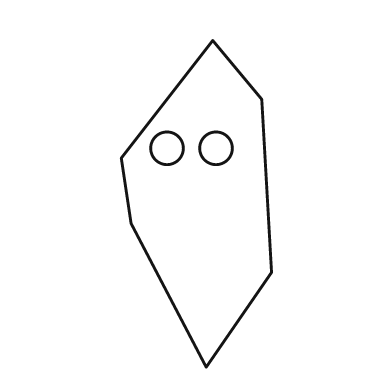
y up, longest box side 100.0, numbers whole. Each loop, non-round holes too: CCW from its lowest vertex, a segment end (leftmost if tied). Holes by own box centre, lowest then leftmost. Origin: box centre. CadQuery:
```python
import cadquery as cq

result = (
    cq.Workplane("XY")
    .moveTo(3.0, -50.0)
    .lineTo(23.0, -21.0)
    .lineTo(20.0, 32.0)
    .lineTo(5.0, 50.0)
    .lineTo(-23.0, 14.0)
    .lineTo(-20.0, -6.0)
    .close()
    .moveTo(-9.0, 17.0)
    .circle(5.0)
    .moveTo(6.0, 17.0)
    .circle(5.0)
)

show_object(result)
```